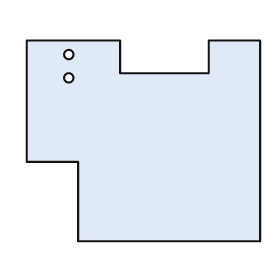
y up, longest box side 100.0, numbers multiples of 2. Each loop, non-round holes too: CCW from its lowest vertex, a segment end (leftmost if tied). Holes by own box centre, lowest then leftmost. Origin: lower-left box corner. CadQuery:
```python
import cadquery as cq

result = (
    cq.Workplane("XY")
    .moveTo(22.0, 0.0)
    .lineTo(100.0, 0.0)
    .lineTo(100.0, 86.0)
    .lineTo(78.0, 86.0)
    .lineTo(78.0, 72.0)
    .lineTo(40.0, 72.0)
    .lineTo(40.0, 86.0)
    .lineTo(0.0, 86.0)
    .lineTo(0.0, 34.0)
    .lineTo(22.0, 34.0)
    .close()
    .moveTo(18.0, 70.0)
    .circle(2.0)
    .moveTo(18.0, 80.0)
    .circle(2.0)
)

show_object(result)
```